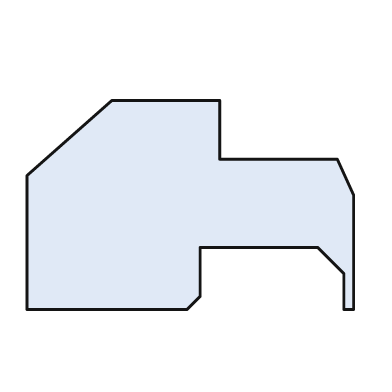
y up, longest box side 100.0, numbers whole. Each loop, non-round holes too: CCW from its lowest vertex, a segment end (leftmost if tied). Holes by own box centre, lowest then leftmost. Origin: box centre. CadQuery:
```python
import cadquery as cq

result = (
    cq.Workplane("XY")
    .moveTo(-50.0, -32.0)
    .lineTo(-1.0, -32.0)
    .lineTo(3.0, -28.0)
    .lineTo(3.0, -13.0)
    .lineTo(39.0, -13.0)
    .lineTo(47.0, -21.0)
    .lineTo(47.0, -32.0)
    .lineTo(50.0, -32.0)
    .lineTo(50.0, 3.0)
    .lineTo(45.0, 14.0)
    .lineTo(9.0, 14.0)
    .lineTo(9.0, 32.0)
    .lineTo(-24.0, 32.0)
    .lineTo(-50.0, 9.0)
    .close()
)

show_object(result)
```